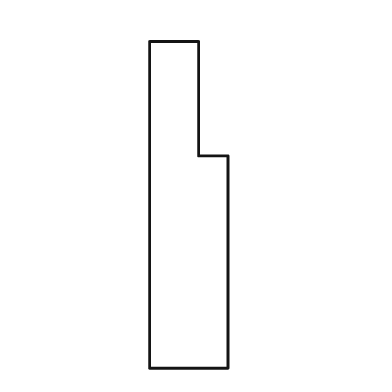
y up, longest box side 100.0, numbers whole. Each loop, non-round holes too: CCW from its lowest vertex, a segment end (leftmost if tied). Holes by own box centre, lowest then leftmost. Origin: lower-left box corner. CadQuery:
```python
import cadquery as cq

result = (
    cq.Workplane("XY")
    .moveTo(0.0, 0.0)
    .lineTo(24.0, 0.0)
    .lineTo(24.0, 65.0)
    .lineTo(15.0, 65.0)
    .lineTo(15.0, 100.0)
    .lineTo(0.0, 100.0)
    .close()
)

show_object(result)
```